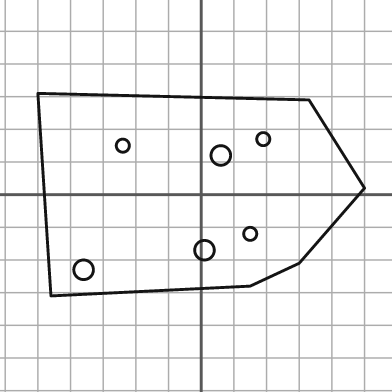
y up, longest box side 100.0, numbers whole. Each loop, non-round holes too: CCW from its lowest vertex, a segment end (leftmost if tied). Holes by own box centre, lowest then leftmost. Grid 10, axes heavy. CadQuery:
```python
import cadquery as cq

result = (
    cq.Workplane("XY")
    .moveTo(-46.0, -31.0)
    .lineTo(15.0, -28.0)
    .lineTo(30.0, -21.0)
    .lineTo(50.0, 2.0)
    .lineTo(33.0, 29.0)
    .lineTo(-50.0, 31.0)
    .close()
    .moveTo(-36.0, -23.0)
    .circle(3.0)
    .moveTo(1.0, -17.0)
    .circle(3.0)
    .moveTo(15.0, -12.0)
    .circle(2.0)
    .moveTo(6.0, 12.0)
    .circle(3.0)
    .moveTo(-24.0, 15.0)
    .circle(2.0)
    .moveTo(19.0, 17.0)
    .circle(2.0)
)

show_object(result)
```